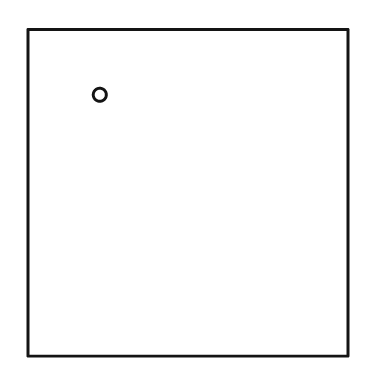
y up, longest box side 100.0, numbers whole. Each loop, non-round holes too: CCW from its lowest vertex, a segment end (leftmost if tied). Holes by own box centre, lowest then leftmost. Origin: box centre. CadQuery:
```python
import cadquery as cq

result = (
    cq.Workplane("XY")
    .moveTo(-49.0, -50.0)
    .lineTo(49.0, -50.0)
    .lineTo(49.0, 50.0)
    .lineTo(-49.0, 50.0)
    .close()
    .moveTo(-27.0, 30.0)
    .circle(2.0)
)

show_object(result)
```